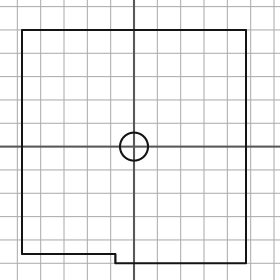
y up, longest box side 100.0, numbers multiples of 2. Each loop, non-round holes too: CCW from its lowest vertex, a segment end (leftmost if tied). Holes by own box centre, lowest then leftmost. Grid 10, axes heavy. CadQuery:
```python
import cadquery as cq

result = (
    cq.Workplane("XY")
    .moveTo(-8.0, -50.0)
    .lineTo(48.0, -50.0)
    .lineTo(48.0, 50.0)
    .lineTo(-48.0, 50.0)
    .lineTo(-48.0, -46.0)
    .lineTo(-8.0, -46.0)
    .close()
    .moveTo(0.0, 0.0)
    .circle(6.0)
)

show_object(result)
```